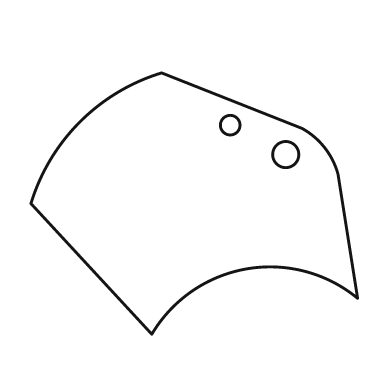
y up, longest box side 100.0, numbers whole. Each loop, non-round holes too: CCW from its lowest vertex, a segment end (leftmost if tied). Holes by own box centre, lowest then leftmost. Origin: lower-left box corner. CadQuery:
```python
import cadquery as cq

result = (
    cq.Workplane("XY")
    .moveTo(37.0, 0.0)
    .threePointArc((66.0, 20.0), (100.0, 11.0))
    .lineTo(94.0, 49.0)
    .threePointArc((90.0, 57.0), (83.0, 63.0))
    .lineTo(40.0, 80.0)
    .threePointArc((15.0, 65.0), (0.0, 40.0))
    .close()
    .moveTo(78.0, 55.0)
    .circle(4.0)
    .moveTo(61.0, 64.0)
    .circle(3.0)
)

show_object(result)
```